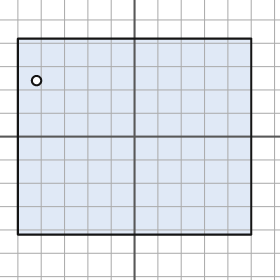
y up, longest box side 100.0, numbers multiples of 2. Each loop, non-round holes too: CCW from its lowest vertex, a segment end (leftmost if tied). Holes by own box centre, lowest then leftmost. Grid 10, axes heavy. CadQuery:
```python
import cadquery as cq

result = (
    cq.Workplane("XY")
    .moveTo(-50.0, -42.0)
    .lineTo(50.0, -42.0)
    .lineTo(50.0, 42.0)
    .lineTo(-50.0, 42.0)
    .close()
    .moveTo(-42.0, 24.0)
    .circle(2.0)
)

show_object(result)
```